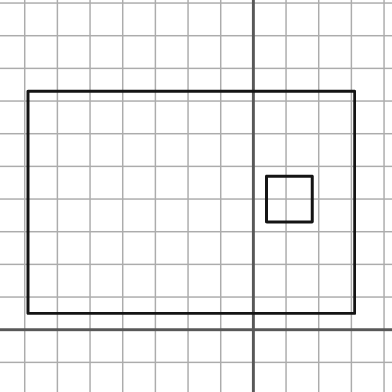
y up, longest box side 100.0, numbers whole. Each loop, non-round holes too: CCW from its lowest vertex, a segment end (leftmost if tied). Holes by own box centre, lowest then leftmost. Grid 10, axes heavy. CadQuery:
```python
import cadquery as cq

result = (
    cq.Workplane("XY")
    .moveTo(-69.0, 5.0)
    .lineTo(31.0, 5.0)
    .lineTo(31.0, 73.0)
    .lineTo(-69.0, 73.0)
    .close()
    .moveTo(4.0, 33.0)
    .lineTo(18.0, 33.0)
    .lineTo(18.0, 47.0)
    .lineTo(4.0, 47.0)
    .close()
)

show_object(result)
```